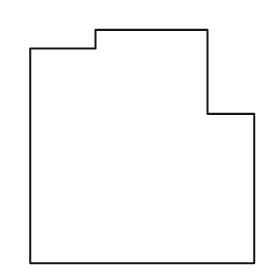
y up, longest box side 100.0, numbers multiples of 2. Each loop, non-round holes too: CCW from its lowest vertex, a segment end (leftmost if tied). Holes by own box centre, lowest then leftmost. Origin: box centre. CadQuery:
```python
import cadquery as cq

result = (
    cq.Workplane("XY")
    .moveTo(-48.0, -50.0)
    .lineTo(48.0, -50.0)
    .lineTo(48.0, 14.0)
    .lineTo(28.0, 14.0)
    .lineTo(28.0, 50.0)
    .lineTo(-20.0, 50.0)
    .lineTo(-20.0, 42.0)
    .lineTo(-48.0, 42.0)
    .close()
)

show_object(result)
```